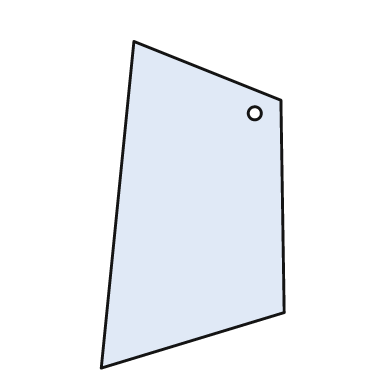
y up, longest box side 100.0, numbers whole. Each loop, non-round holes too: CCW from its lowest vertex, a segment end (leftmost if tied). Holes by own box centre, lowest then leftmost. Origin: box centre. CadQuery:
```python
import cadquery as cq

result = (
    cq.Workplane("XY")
    .moveTo(-28.0, -50.0)
    .lineTo(28.0, -33.0)
    .lineTo(27.0, 32.0)
    .lineTo(-18.0, 50.0)
    .close()
    .moveTo(19.0, 28.0)
    .circle(2.0)
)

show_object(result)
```